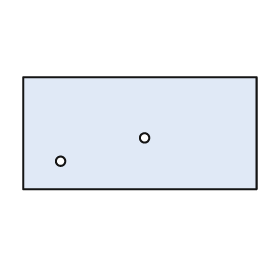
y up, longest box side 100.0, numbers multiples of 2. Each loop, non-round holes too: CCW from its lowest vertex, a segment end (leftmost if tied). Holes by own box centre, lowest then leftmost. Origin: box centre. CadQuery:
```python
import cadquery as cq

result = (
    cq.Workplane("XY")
    .moveTo(-50.0, -24.0)
    .lineTo(50.0, -24.0)
    .lineTo(50.0, 24.0)
    .lineTo(-50.0, 24.0)
    .close()
    .moveTo(-34.0, -12.0)
    .circle(2.0)
    .moveTo(2.0, -2.0)
    .circle(2.0)
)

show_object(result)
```